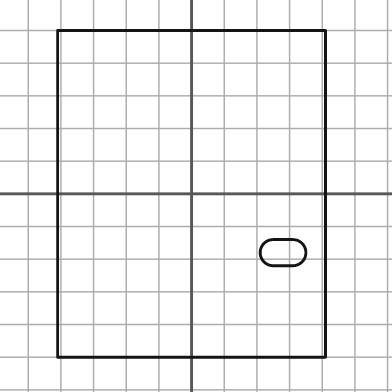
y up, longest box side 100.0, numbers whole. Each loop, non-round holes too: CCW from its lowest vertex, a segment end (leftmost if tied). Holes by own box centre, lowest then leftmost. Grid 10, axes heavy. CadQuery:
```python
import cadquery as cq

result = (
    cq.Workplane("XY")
    .moveTo(-41.0, -50.0)
    .lineTo(41.0, -50.0)
    .lineTo(41.0, 50.0)
    .lineTo(-41.0, 50.0)
    .close()
    .moveTo(25.0, -22.0)
    .lineTo(31.0, -22.0)
    .threePointArc((35.0, -18.0), (31.0, -14.0))
    .lineTo(25.0, -14.0)
    .threePointArc((21.0, -18.0), (25.0, -22.0))
    .close()
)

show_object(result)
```